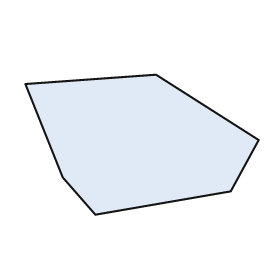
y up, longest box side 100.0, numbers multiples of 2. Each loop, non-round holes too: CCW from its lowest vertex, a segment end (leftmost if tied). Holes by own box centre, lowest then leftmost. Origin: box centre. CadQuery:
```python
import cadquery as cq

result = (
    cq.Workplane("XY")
    .moveTo(-20.0, -30.0)
    .lineTo(38.0, -20.0)
    .lineTo(50.0, 2.0)
    .lineTo(6.0, 30.0)
    .lineTo(-50.0, 26.0)
    .lineTo(-34.0, -14.0)
    .close()
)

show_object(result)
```